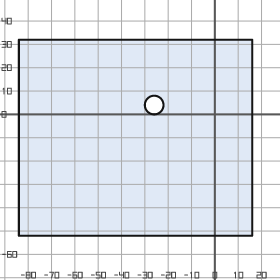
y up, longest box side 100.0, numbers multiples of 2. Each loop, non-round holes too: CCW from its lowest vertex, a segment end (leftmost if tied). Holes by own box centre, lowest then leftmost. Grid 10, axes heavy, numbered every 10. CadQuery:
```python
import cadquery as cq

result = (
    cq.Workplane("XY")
    .moveTo(-84.0, -52.0)
    .lineTo(16.0, -52.0)
    .lineTo(16.0, 32.0)
    .lineTo(-84.0, 32.0)
    .close()
    .moveTo(-26.0, 4.0)
    .circle(4.0)
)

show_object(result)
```